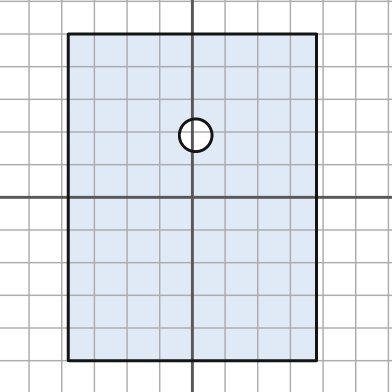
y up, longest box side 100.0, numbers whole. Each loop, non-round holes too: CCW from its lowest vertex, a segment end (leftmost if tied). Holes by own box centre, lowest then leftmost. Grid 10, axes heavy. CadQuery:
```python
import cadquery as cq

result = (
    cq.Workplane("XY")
    .moveTo(-38.0, -50.0)
    .lineTo(38.0, -50.0)
    .lineTo(38.0, 50.0)
    .lineTo(-38.0, 50.0)
    .close()
    .moveTo(1.0, 19.0)
    .circle(5.0)
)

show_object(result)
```